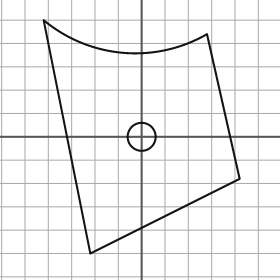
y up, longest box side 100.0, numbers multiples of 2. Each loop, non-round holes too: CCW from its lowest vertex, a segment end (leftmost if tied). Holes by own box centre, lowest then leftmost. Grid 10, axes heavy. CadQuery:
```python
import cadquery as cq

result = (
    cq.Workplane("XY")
    .moveTo(-22.0, -50.0)
    .lineTo(42.0, -18.0)
    .lineTo(28.0, 44.0)
    .threePointArc((-8.0, 36.0), (-42.0, 50.0))
    .close()
    .moveTo(0.0, 0.0)
    .circle(6.0)
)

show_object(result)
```